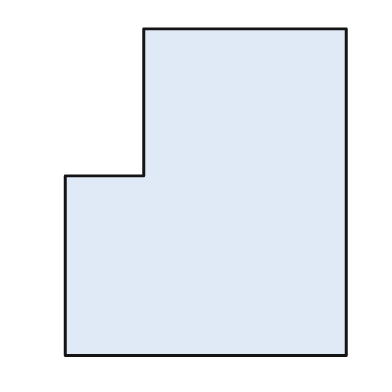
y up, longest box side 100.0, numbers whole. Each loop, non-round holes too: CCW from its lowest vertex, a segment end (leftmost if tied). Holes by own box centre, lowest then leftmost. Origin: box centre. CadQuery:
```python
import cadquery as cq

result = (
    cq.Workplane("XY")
    .moveTo(-43.0, -50.0)
    .lineTo(43.0, -50.0)
    .lineTo(43.0, 50.0)
    .lineTo(-19.0, 50.0)
    .lineTo(-19.0, 5.0)
    .lineTo(-43.0, 5.0)
    .close()
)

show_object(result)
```